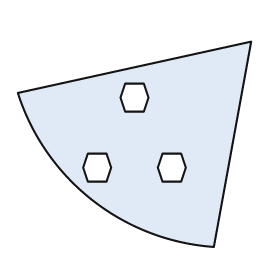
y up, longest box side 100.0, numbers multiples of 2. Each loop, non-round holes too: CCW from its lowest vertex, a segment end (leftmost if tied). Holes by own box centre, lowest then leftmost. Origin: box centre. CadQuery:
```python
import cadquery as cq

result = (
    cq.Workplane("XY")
    .moveTo(34.0, -44.0)
    .lineTo(50.0, 44.0)
    .lineTo(-50.0, 22.0)
    .threePointArc((-18.0, -24.0), (34.0, -44.0))
    .close()
    .moveTo(-20.0, -16.0)
    .lineTo(-12.0, -16.0)
    .lineTo(-10.0, -10.0)
    .lineTo(-12.0, -4.0)
    .lineTo(-20.0, -4.0)
    .lineTo(-22.0, -10.0)
    .close()
    .moveTo(12.0, -16.0)
    .lineTo(20.0, -16.0)
    .lineTo(22.0, -10.0)
    .lineTo(20.0, -4.0)
    .lineTo(12.0, -4.0)
    .lineTo(10.0, -10.0)
    .close()
    .moveTo(-4.0, 14.0)
    .lineTo(4.0, 14.0)
    .lineTo(6.0, 20.0)
    .lineTo(4.0, 26.0)
    .lineTo(-4.0, 26.0)
    .lineTo(-6.0, 20.0)
    .close()
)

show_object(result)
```